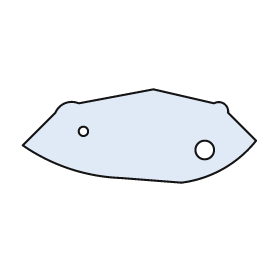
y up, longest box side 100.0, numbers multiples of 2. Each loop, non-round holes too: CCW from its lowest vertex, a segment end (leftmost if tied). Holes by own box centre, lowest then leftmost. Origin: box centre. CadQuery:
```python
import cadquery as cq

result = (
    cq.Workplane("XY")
    .moveTo(18.0, -20.0)
    .threePointArc((36.0, -14.0), (50.0, -2.0))
    .lineTo(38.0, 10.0)
    .threePointArc((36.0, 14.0), (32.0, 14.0))
    .lineTo(6.0, 20.0)
    .lineTo(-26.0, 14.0)
    .threePointArc((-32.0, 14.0), (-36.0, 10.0))
    .lineTo(-50.0, -4.0)
    .threePointArc((-30.0, -14.0), (-8.0, -18.0))
    .close()
    .moveTo(28.0, -6.0)
    .circle(4.0)
    .moveTo(-24.0, 2.0)
    .circle(2.0)
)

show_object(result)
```